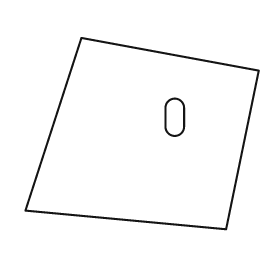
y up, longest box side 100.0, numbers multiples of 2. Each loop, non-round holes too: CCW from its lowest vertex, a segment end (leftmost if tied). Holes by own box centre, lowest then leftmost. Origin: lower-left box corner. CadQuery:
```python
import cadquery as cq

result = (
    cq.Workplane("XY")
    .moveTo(86.0, 0.0)
    .lineTo(100.0, 68.0)
    .lineTo(24.0, 82.0)
    .lineTo(0.0, 8.0)
    .close()
    .moveTo(60.0, 44.0)
    .threePointArc((64.0, 40.0), (68.0, 44.0))
    .lineTo(68.0, 52.0)
    .threePointArc((64.0, 56.0), (60.0, 52.0))
    .close()
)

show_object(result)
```